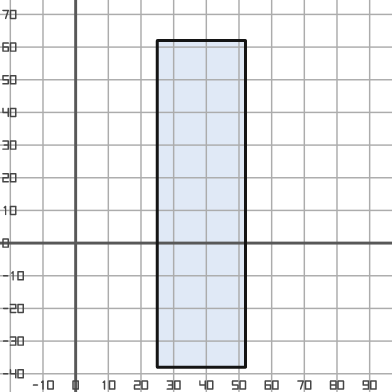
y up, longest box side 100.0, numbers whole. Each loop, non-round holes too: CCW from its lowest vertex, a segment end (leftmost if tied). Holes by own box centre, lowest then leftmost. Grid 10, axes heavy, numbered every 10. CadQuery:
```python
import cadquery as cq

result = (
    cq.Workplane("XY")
    .moveTo(25.0, -38.0)
    .lineTo(52.0, -38.0)
    .lineTo(52.0, 62.0)
    .lineTo(25.0, 62.0)
    .close()
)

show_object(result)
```